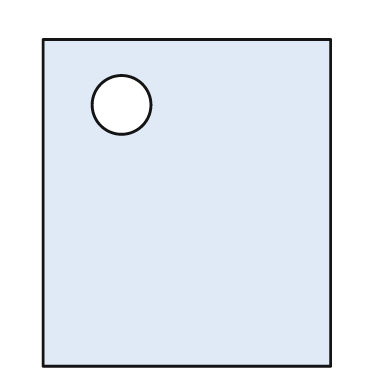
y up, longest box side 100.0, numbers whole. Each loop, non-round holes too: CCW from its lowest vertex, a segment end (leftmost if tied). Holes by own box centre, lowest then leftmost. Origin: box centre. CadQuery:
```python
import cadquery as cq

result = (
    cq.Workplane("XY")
    .moveTo(-44.0, -50.0)
    .lineTo(44.0, -50.0)
    .lineTo(44.0, 50.0)
    .lineTo(-44.0, 50.0)
    .close()
    .moveTo(-20.0, 30.0)
    .circle(9.0)
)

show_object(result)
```